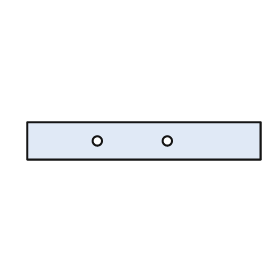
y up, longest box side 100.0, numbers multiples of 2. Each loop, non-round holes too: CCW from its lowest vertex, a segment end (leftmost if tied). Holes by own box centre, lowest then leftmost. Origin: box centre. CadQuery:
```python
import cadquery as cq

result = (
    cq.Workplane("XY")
    .moveTo(-50.0, -8.0)
    .lineTo(50.0, -8.0)
    .lineTo(50.0, 8.0)
    .lineTo(-50.0, 8.0)
    .close()
    .moveTo(-20.0, 0.0)
    .circle(2.0)
    .moveTo(10.0, 0.0)
    .circle(2.0)
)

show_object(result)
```